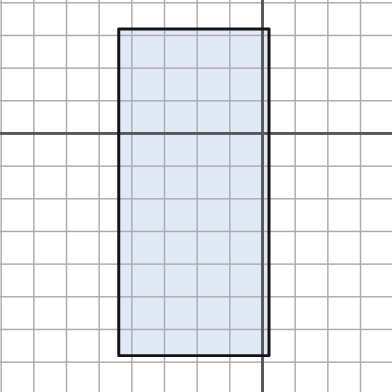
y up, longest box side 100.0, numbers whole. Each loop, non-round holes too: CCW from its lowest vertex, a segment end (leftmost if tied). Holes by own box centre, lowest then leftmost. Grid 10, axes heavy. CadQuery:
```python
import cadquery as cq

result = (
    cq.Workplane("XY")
    .moveTo(-44.0, -68.0)
    .lineTo(2.0, -68.0)
    .lineTo(2.0, 32.0)
    .lineTo(-44.0, 32.0)
    .close()
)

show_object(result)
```